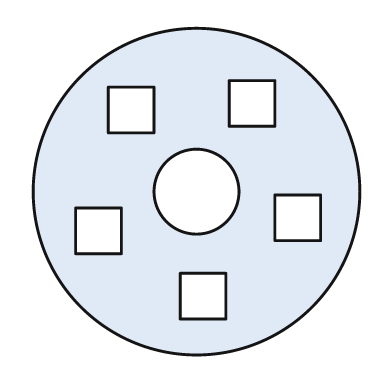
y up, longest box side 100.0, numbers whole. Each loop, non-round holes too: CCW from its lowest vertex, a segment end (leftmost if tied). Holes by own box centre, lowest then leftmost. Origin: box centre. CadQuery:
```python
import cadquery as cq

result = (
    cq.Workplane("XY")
    .moveTo(0.0, 0.0)
    .circle(50.0)
    .moveTo(-5.0, -39.0)
    .lineTo(9.0, -39.0)
    .lineTo(9.0, -25.0)
    .lineTo(-5.0, -25.0)
    .close()
    .moveTo(-37.0, -19.0)
    .lineTo(-23.0, -19.0)
    .lineTo(-23.0, -5.0)
    .lineTo(-37.0, -5.0)
    .close()
    .moveTo(24.0, -15.0)
    .lineTo(38.0, -15.0)
    .lineTo(38.0, -1.0)
    .lineTo(24.0, -1.0)
    .close()
    .moveTo(0.0, 0.0)
    .circle(13.0)
    .moveTo(-27.0, 18.0)
    .lineTo(-13.0, 18.0)
    .lineTo(-13.0, 32.0)
    .lineTo(-27.0, 32.0)
    .close()
    .moveTo(10.0, 20.0)
    .lineTo(24.0, 20.0)
    .lineTo(24.0, 34.0)
    .lineTo(10.0, 34.0)
    .close()
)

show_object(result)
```